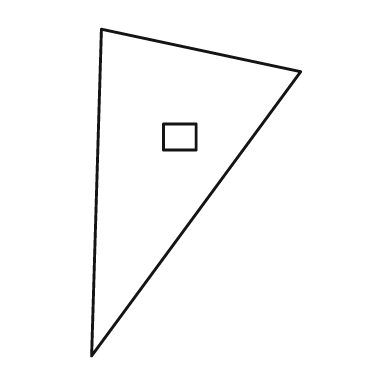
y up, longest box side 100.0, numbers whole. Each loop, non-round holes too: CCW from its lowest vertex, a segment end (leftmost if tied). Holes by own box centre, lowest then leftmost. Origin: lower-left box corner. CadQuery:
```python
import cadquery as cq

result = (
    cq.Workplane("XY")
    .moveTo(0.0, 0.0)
    .lineTo(64.0, 87.0)
    .lineTo(3.0, 100.0)
    .close()
    .moveTo(22.0, 63.0)
    .lineTo(32.0, 63.0)
    .lineTo(32.0, 71.0)
    .lineTo(22.0, 71.0)
    .close()
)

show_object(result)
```